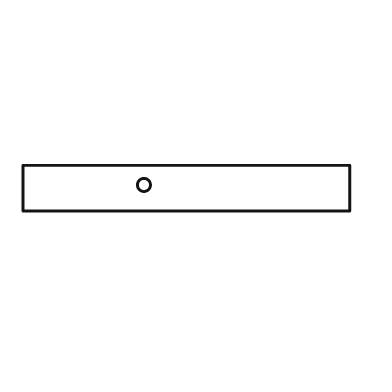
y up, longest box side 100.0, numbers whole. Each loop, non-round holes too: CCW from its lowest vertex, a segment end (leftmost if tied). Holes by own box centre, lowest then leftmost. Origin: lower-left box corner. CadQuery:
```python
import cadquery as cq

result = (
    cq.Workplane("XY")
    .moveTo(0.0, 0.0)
    .lineTo(100.0, 0.0)
    .lineTo(100.0, 14.0)
    .lineTo(0.0, 14.0)
    .close()
    .moveTo(37.0, 8.0)
    .circle(2.0)
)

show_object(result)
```